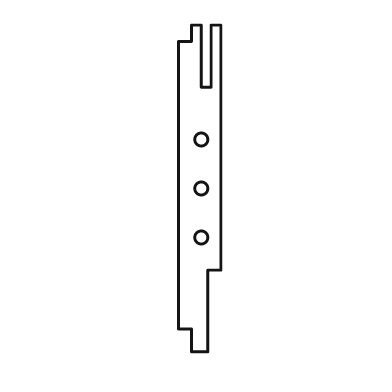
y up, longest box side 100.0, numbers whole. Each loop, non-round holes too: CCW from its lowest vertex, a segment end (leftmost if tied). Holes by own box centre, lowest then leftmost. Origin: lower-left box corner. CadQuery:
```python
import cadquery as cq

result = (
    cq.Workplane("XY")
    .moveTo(4.0, 0.0)
    .lineTo(9.0, 0.0)
    .lineTo(9.0, 25.0)
    .lineTo(13.0, 25.0)
    .lineTo(13.0, 100.0)
    .lineTo(10.0, 100.0)
    .lineTo(10.0, 81.0)
    .lineTo(7.0, 81.0)
    .lineTo(7.0, 100.0)
    .lineTo(4.0, 100.0)
    .lineTo(4.0, 95.0)
    .lineTo(0.0, 95.0)
    .lineTo(0.0, 7.0)
    .lineTo(4.0, 7.0)
    .close()
    .moveTo(7.0, 35.0)
    .circle(2.0)
    .moveTo(7.0, 50.0)
    .circle(2.0)
    .moveTo(7.0, 65.0)
    .circle(2.0)
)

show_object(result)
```